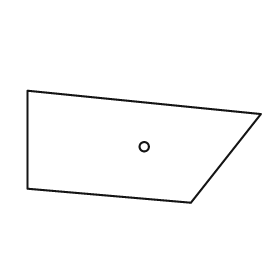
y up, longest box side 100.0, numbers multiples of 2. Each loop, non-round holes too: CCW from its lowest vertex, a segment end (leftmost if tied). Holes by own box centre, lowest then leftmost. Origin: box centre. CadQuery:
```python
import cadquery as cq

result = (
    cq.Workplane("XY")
    .moveTo(20.0, -24.0)
    .lineTo(50.0, 14.0)
    .lineTo(-50.0, 24.0)
    .lineTo(-50.0, -18.0)
    .close()
    .moveTo(0.0, 0.0)
    .circle(2.0)
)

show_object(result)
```